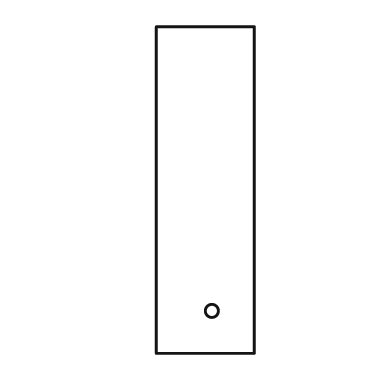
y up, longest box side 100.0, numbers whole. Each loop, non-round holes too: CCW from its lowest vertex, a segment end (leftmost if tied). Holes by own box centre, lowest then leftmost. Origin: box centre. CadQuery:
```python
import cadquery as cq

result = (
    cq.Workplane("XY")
    .moveTo(-15.0, -50.0)
    .lineTo(15.0, -50.0)
    .lineTo(15.0, 50.0)
    .lineTo(-15.0, 50.0)
    .close()
    .moveTo(2.0, -37.0)
    .circle(2.0)
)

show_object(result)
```